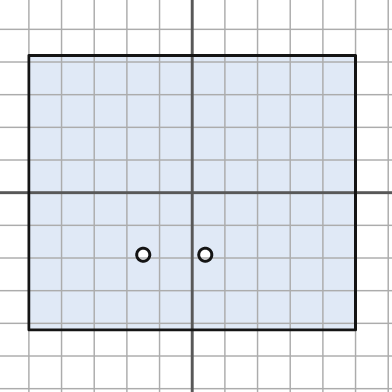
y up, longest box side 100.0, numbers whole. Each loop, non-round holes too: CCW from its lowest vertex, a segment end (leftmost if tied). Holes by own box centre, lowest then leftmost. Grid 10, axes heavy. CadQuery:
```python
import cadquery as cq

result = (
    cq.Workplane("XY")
    .moveTo(-50.0, -42.0)
    .lineTo(50.0, -42.0)
    .lineTo(50.0, 42.0)
    .lineTo(-50.0, 42.0)
    .close()
    .moveTo(-15.0, -19.0)
    .circle(2.0)
    .moveTo(4.0, -19.0)
    .circle(2.0)
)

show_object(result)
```